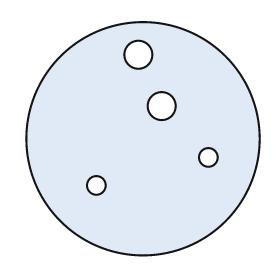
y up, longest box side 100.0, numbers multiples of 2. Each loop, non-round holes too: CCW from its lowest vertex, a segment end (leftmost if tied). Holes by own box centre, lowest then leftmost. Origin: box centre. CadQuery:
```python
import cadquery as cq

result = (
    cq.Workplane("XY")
    .moveTo(0.0, 0.0)
    .circle(50.0)
    .moveTo(-20.0, -20.0)
    .circle(4.0)
    .moveTo(28.0, -8.0)
    .circle(4.0)
    .moveTo(8.0, 14.0)
    .circle(6.0)
    .moveTo(-2.0, 36.0)
    .circle(6.0)
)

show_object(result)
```